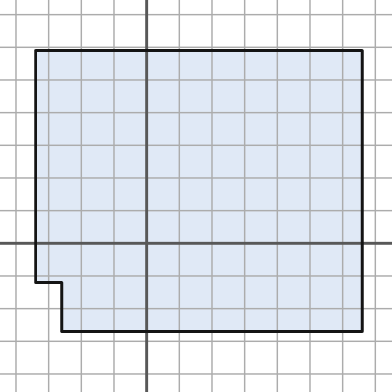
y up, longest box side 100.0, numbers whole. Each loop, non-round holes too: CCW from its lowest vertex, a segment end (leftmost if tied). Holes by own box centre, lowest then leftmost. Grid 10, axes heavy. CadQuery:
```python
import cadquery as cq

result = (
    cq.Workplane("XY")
    .moveTo(-26.0, -27.0)
    .lineTo(66.0, -27.0)
    .lineTo(66.0, 59.0)
    .lineTo(-34.0, 59.0)
    .lineTo(-34.0, -12.0)
    .lineTo(-26.0, -12.0)
    .close()
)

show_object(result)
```